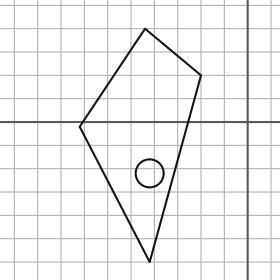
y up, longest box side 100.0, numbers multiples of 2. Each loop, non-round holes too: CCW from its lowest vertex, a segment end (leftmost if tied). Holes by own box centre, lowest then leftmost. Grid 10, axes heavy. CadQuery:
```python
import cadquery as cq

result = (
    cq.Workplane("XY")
    .moveTo(-42.0, -60.0)
    .lineTo(-20.0, 20.0)
    .lineTo(-44.0, 40.0)
    .lineTo(-72.0, -2.0)
    .close()
    .moveTo(-42.0, -22.0)
    .circle(6.0)
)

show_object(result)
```